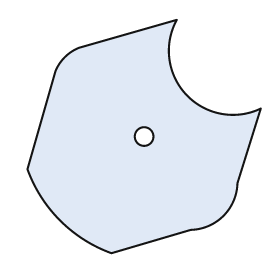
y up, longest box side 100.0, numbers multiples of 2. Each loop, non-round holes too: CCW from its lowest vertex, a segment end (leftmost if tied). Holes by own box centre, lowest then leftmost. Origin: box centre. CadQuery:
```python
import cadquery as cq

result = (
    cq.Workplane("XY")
    .moveTo(-14.0, -50.0)
    .lineTo(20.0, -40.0)
    .threePointArc((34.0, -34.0), (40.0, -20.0))
    .lineTo(50.0, 12.0)
    .threePointArc((18.0, 18.0), (14.0, 50.0))
    .lineTo(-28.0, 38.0)
    .threePointArc((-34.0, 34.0), (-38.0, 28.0))
    .lineTo(-50.0, -14.0)
    .threePointArc((-36.0, -36.0), (-14.0, -50.0))
    .close()
    .moveTo(0.0, 0.0)
    .circle(4.0)
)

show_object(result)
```